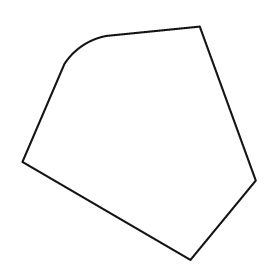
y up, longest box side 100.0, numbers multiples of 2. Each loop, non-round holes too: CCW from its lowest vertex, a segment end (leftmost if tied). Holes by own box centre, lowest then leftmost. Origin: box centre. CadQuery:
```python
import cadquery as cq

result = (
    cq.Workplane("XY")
    .moveTo(22.0, -50.0)
    .lineTo(50.0, -16.0)
    .lineTo(26.0, 50.0)
    .lineTo(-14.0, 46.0)
    .threePointArc((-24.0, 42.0), (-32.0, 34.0))
    .lineTo(-50.0, -8.0)
    .close()
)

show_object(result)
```